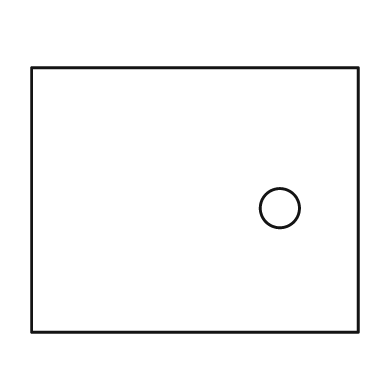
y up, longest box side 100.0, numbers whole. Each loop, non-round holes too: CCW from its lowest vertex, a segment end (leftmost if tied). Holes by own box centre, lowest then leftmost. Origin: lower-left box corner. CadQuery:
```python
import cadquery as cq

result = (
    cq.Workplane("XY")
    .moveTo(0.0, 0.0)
    .lineTo(100.0, 0.0)
    .lineTo(100.0, 81.0)
    .lineTo(0.0, 81.0)
    .close()
    .moveTo(76.0, 38.0)
    .circle(6.0)
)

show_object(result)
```